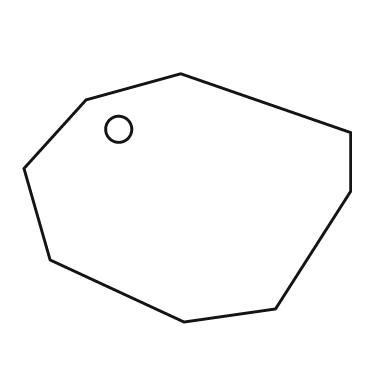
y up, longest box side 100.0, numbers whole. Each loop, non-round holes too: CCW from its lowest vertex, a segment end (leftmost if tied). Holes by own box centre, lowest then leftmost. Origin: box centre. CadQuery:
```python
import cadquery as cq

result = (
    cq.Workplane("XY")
    .moveTo(-1.0, -38.0)
    .lineTo(27.0, -34.0)
    .lineTo(50.0, 2.0)
    .lineTo(50.0, 20.0)
    .lineTo(-2.0, 38.0)
    .lineTo(-31.0, 30.0)
    .lineTo(-50.0, 9.0)
    .lineTo(-42.0, -19.0)
    .close()
    .moveTo(-21.0, 21.0)
    .circle(4.0)
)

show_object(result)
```